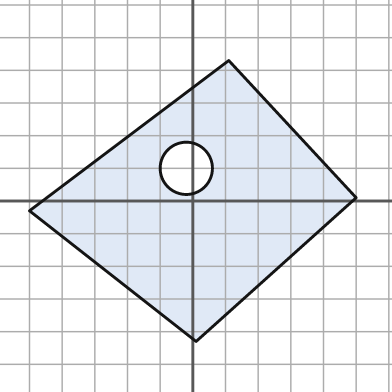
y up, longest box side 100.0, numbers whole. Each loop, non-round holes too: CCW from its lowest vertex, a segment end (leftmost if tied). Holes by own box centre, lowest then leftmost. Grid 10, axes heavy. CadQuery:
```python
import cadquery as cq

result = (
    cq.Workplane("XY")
    .moveTo(1.0, -43.0)
    .lineTo(50.0, 1.0)
    .lineTo(11.0, 43.0)
    .lineTo(-50.0, -3.0)
    .close()
    .moveTo(-2.0, 10.0)
    .circle(8.0)
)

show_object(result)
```